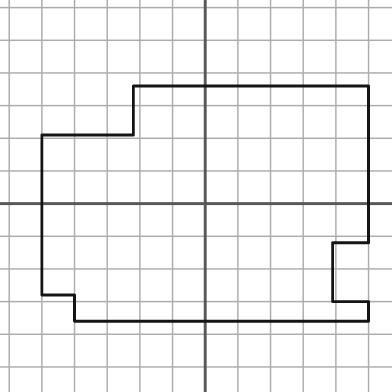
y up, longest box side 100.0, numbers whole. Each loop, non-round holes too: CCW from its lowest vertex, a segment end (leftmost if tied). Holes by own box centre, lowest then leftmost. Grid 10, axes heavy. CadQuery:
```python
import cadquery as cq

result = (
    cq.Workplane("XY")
    .moveTo(-40.0, -36.0)
    .lineTo(50.0, -36.0)
    .lineTo(50.0, -30.0)
    .lineTo(39.0, -30.0)
    .lineTo(39.0, -12.0)
    .lineTo(50.0, -12.0)
    .lineTo(50.0, 36.0)
    .lineTo(-22.0, 36.0)
    .lineTo(-22.0, 21.0)
    .lineTo(-50.0, 21.0)
    .lineTo(-50.0, -28.0)
    .lineTo(-40.0, -28.0)
    .close()
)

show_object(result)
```